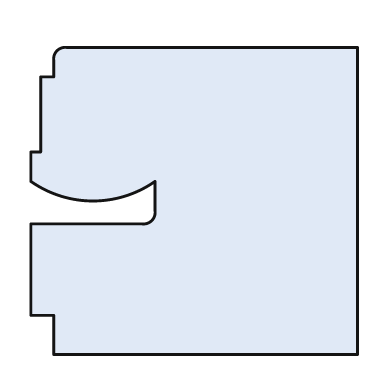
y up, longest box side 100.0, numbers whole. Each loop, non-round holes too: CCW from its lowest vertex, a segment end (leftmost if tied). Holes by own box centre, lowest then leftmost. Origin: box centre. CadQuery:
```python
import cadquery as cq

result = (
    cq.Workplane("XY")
    .moveTo(-43.0, -47.0)
    .lineTo(50.0, -47.0)
    .lineTo(50.0, 47.0)
    .lineTo(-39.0, 47.0)
    .threePointArc((-42.0, 46.0), (-43.0, 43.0))
    .lineTo(-43.0, 38.0)
    .lineTo(-47.0, 38.0)
    .lineTo(-47.0, 15.0)
    .lineTo(-50.0, 15.0)
    .lineTo(-50.0, 6.0)
    .threePointArc((-31.0, 0.0), (-12.0, 6.0))
    .lineTo(-12.0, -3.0)
    .threePointArc((-13.0, -6.0), (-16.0, -7.0))
    .lineTo(-50.0, -7.0)
    .lineTo(-50.0, -35.0)
    .lineTo(-43.0, -35.0)
    .close()
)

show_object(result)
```